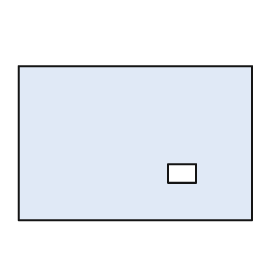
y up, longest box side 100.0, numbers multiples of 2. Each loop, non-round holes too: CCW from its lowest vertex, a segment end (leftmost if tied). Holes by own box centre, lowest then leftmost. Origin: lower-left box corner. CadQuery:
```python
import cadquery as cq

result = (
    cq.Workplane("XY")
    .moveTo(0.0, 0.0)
    .lineTo(100.0, 0.0)
    .lineTo(100.0, 66.0)
    .lineTo(0.0, 66.0)
    .close()
    .moveTo(64.0, 16.0)
    .lineTo(76.0, 16.0)
    .lineTo(76.0, 24.0)
    .lineTo(64.0, 24.0)
    .close()
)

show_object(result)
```